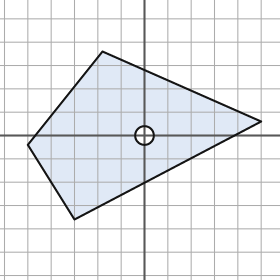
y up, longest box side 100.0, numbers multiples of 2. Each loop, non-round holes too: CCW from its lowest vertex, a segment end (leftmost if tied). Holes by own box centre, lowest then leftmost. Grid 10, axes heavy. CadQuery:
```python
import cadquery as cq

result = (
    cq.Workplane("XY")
    .moveTo(-30.0, -36.0)
    .lineTo(50.0, 6.0)
    .lineTo(-18.0, 36.0)
    .lineTo(-50.0, -4.0)
    .close()
    .moveTo(0.0, 0.0)
    .circle(4.0)
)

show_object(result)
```